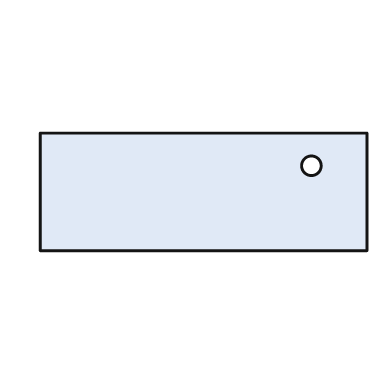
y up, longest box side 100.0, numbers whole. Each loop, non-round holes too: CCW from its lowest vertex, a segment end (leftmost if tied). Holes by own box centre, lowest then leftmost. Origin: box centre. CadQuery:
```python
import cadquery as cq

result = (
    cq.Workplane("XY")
    .moveTo(-50.0, -18.0)
    .lineTo(50.0, -18.0)
    .lineTo(50.0, 18.0)
    .lineTo(-50.0, 18.0)
    .close()
    .moveTo(33.0, 8.0)
    .circle(3.0)
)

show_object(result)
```